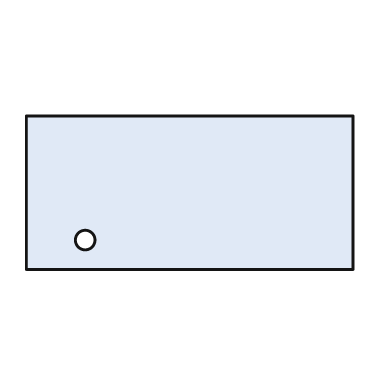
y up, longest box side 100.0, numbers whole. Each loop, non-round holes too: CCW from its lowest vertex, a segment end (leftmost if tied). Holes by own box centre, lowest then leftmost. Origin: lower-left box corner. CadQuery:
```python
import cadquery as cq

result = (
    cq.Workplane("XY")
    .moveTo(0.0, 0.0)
    .lineTo(100.0, 0.0)
    .lineTo(100.0, 47.0)
    .lineTo(0.0, 47.0)
    .close()
    .moveTo(18.0, 9.0)
    .circle(3.0)
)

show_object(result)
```